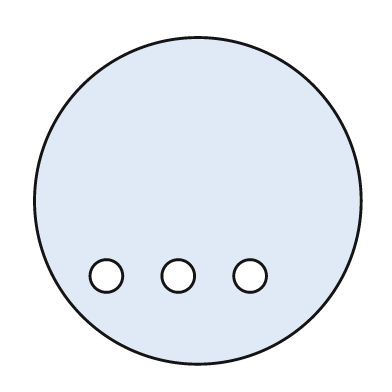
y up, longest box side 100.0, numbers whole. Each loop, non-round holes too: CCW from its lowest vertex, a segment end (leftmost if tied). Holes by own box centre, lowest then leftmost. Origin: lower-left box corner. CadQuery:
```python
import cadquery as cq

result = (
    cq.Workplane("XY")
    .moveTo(50.0, 50.0)
    .circle(50.0)
    .moveTo(22.0, 27.0)
    .circle(5.0)
    .moveTo(44.0, 27.0)
    .circle(5.0)
    .moveTo(66.0, 27.0)
    .circle(5.0)
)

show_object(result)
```